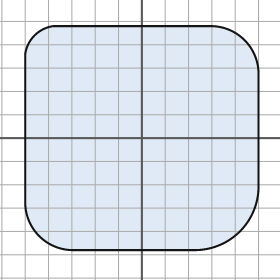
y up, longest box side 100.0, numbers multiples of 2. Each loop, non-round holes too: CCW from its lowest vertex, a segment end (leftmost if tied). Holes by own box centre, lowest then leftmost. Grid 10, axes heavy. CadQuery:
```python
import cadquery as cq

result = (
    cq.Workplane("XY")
    .moveTo(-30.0, -48.0)
    .lineTo(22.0, -48.0)
    .threePointArc((42.0, -40.0), (50.0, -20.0))
    .lineTo(50.0, 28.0)
    .threePointArc((44.0, 42.0), (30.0, 48.0))
    .lineTo(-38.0, 48.0)
    .threePointArc((-46.0, 44.0), (-50.0, 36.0))
    .lineTo(-50.0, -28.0)
    .threePointArc((-44.0, -42.0), (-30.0, -48.0))
    .close()
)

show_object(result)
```